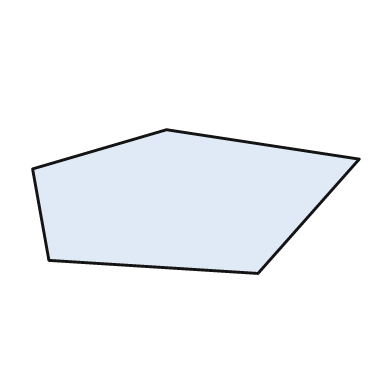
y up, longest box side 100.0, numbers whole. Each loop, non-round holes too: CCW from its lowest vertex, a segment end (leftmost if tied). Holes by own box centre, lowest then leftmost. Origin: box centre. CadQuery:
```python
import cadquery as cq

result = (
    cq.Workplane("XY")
    .moveTo(19.0, -22.0)
    .lineTo(50.0, 13.0)
    .lineTo(-9.0, 22.0)
    .lineTo(-50.0, 10.0)
    .lineTo(-45.0, -18.0)
    .close()
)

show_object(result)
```